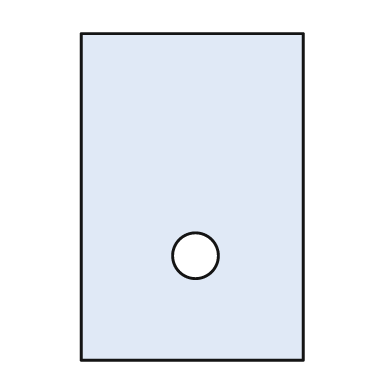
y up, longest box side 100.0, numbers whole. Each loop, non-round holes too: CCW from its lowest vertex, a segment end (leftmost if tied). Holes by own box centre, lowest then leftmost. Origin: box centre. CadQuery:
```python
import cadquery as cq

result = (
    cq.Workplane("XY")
    .moveTo(-34.0, -50.0)
    .lineTo(34.0, -50.0)
    .lineTo(34.0, 50.0)
    .lineTo(-34.0, 50.0)
    .close()
    .moveTo(1.0, -18.0)
    .circle(7.0)
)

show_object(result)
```